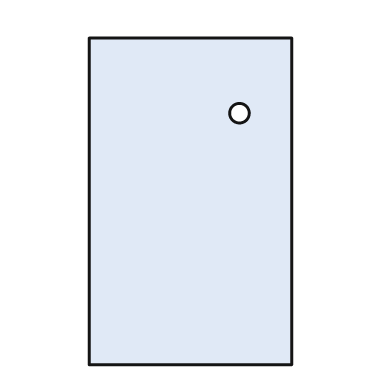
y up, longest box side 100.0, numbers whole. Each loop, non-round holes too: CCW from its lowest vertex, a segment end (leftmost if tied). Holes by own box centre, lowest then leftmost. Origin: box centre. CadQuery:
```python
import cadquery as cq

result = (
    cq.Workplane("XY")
    .moveTo(-31.0, -50.0)
    .lineTo(31.0, -50.0)
    .lineTo(31.0, 50.0)
    .lineTo(-31.0, 50.0)
    .close()
    .moveTo(15.0, 27.0)
    .circle(3.0)
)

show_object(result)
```